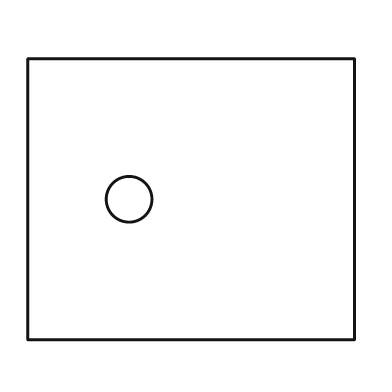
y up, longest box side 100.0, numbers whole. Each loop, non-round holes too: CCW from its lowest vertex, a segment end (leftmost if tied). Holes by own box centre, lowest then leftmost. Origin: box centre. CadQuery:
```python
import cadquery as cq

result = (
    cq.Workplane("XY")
    .moveTo(-50.0, -43.0)
    .lineTo(50.0, -43.0)
    .lineTo(50.0, 43.0)
    .lineTo(-50.0, 43.0)
    .close()
    .moveTo(-19.0, 0.0)
    .circle(7.0)
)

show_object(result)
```